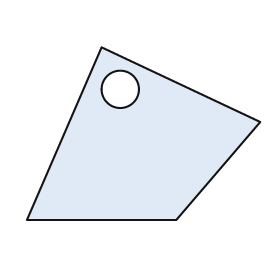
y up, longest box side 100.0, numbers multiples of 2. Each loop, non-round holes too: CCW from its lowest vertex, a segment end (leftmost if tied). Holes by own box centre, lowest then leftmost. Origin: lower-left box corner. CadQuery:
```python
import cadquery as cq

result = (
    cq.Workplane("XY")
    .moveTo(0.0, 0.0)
    .lineTo(64.0, 0.0)
    .lineTo(100.0, 42.0)
    .lineTo(32.0, 74.0)
    .close()
    .moveTo(40.0, 56.0)
    .circle(8.0)
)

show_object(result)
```